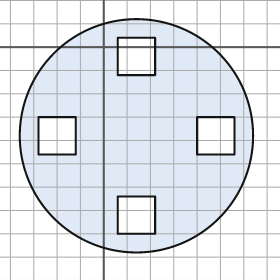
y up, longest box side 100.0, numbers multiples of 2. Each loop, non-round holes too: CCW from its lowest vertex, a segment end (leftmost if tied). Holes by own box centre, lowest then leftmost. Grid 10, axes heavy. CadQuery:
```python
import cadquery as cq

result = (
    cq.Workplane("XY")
    .moveTo(14.0, -38.0)
    .circle(50.0)
    .moveTo(6.0, -80.0)
    .lineTo(22.0, -80.0)
    .lineTo(22.0, -64.0)
    .lineTo(6.0, -64.0)
    .close()
    .moveTo(-28.0, -46.0)
    .lineTo(-12.0, -46.0)
    .lineTo(-12.0, -30.0)
    .lineTo(-28.0, -30.0)
    .close()
    .moveTo(40.0, -46.0)
    .lineTo(56.0, -46.0)
    .lineTo(56.0, -30.0)
    .lineTo(40.0, -30.0)
    .close()
    .moveTo(6.0, -12.0)
    .lineTo(22.0, -12.0)
    .lineTo(22.0, 4.0)
    .lineTo(6.0, 4.0)
    .close()
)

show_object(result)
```